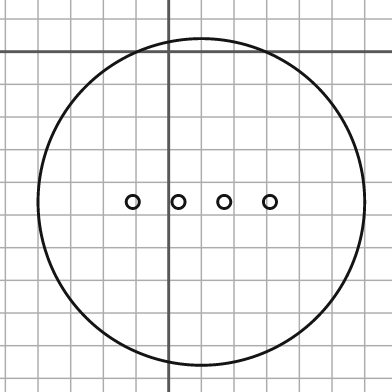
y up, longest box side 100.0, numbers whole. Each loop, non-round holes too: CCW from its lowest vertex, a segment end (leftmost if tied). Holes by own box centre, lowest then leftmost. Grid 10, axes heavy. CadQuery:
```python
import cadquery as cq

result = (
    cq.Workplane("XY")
    .moveTo(10.0, -46.0)
    .circle(50.0)
    .moveTo(-11.0, -46.0)
    .circle(2.0)
    .moveTo(3.0, -46.0)
    .circle(2.0)
    .moveTo(17.0, -46.0)
    .circle(2.0)
    .moveTo(31.0, -46.0)
    .circle(2.0)
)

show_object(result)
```